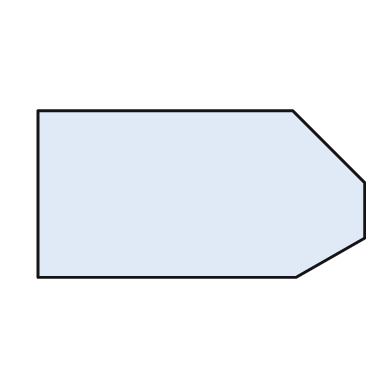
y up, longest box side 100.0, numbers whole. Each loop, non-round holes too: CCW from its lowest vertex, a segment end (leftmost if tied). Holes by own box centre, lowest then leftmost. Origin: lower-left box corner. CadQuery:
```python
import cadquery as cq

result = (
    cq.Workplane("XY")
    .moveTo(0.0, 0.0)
    .lineTo(79.0, 0.0)
    .lineTo(100.0, 12.0)
    .lineTo(100.0, 29.0)
    .lineTo(78.0, 51.0)
    .lineTo(0.0, 51.0)
    .close()
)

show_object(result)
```